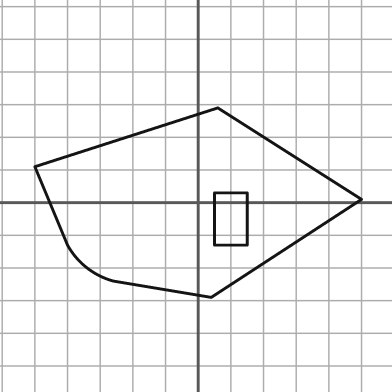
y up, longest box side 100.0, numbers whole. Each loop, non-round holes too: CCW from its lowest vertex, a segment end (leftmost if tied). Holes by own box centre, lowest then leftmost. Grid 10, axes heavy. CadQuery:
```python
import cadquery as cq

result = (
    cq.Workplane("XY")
    .moveTo(4.0, -29.0)
    .lineTo(50.0, 1.0)
    .lineTo(6.0, 29.0)
    .lineTo(-50.0, 11.0)
    .lineTo(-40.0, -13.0)
    .threePointArc((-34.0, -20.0), (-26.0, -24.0))
    .close()
    .moveTo(5.0, -13.0)
    .lineTo(15.0, -13.0)
    .lineTo(15.0, 3.0)
    .lineTo(5.0, 3.0)
    .close()
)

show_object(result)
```